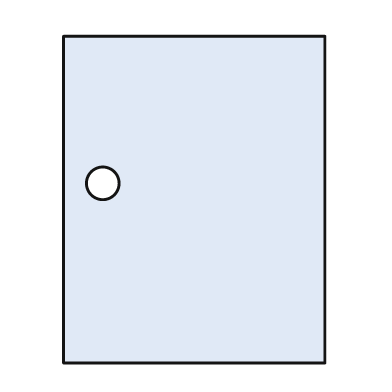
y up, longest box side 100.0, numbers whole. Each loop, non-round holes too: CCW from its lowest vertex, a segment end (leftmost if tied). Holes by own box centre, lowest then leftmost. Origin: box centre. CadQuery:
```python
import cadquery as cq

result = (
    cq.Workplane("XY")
    .moveTo(-40.0, -50.0)
    .lineTo(40.0, -50.0)
    .lineTo(40.0, 50.0)
    .lineTo(-40.0, 50.0)
    .close()
    .moveTo(-28.0, 5.0)
    .circle(5.0)
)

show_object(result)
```